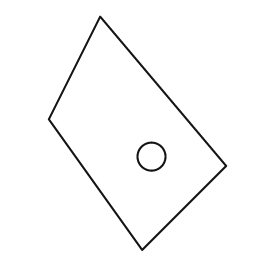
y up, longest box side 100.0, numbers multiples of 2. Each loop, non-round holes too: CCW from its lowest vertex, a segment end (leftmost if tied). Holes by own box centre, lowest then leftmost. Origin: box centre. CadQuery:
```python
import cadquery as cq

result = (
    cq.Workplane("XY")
    .moveTo(2.0, -50.0)
    .lineTo(38.0, -14.0)
    .lineTo(-16.0, 50.0)
    .lineTo(-38.0, 6.0)
    .close()
    .moveTo(6.0, -10.0)
    .circle(6.0)
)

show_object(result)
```